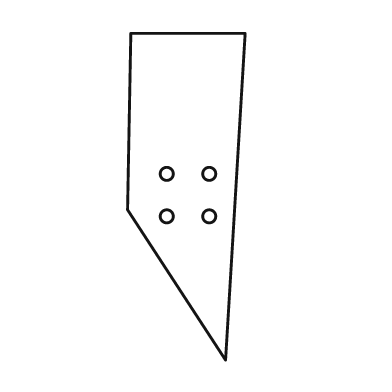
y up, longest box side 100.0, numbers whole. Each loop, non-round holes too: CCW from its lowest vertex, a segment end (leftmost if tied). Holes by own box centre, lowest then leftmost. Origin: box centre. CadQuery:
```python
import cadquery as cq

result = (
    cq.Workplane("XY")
    .moveTo(12.0, -50.0)
    .lineTo(18.0, 50.0)
    .lineTo(-17.0, 50.0)
    .lineTo(-18.0, -4.0)
    .close()
    .moveTo(-6.0, -6.0)
    .circle(2.0)
    .moveTo(7.0, -6.0)
    .circle(2.0)
    .moveTo(-6.0, 7.0)
    .circle(2.0)
    .moveTo(7.0, 7.0)
    .circle(2.0)
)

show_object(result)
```